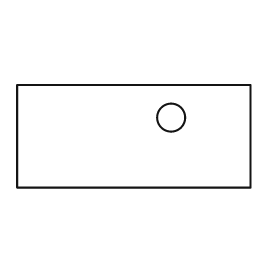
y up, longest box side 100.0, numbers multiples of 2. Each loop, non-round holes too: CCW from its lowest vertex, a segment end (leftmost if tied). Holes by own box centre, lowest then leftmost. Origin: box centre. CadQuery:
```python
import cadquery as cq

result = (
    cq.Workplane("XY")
    .moveTo(-50.0, -22.0)
    .lineTo(50.0, -22.0)
    .lineTo(50.0, 22.0)
    .lineTo(-50.0, 22.0)
    .close()
    .moveTo(16.0, 8.0)
    .circle(6.0)
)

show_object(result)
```